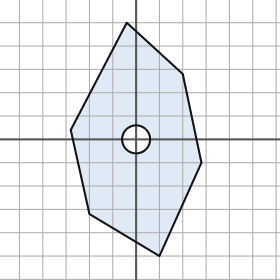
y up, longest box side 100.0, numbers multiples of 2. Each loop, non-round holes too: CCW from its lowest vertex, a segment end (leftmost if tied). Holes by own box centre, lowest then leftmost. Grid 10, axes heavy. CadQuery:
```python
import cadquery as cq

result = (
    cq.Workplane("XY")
    .moveTo(10.0, -50.0)
    .lineTo(28.0, -10.0)
    .lineTo(20.0, 28.0)
    .lineTo(-4.0, 50.0)
    .lineTo(-28.0, 4.0)
    .lineTo(-20.0, -32.0)
    .close()
    .moveTo(0.0, 0.0)
    .circle(6.0)
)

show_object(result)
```